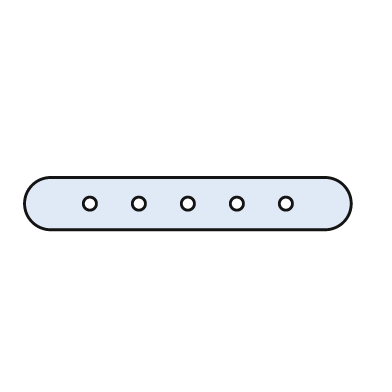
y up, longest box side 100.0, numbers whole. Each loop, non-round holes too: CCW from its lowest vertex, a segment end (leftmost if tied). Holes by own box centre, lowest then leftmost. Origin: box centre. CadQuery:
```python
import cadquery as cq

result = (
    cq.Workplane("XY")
    .moveTo(-42.0, -8.0)
    .lineTo(42.0, -8.0)
    .threePointArc((50.0, 0.0), (42.0, 8.0))
    .lineTo(-42.0, 8.0)
    .threePointArc((-50.0, 0.0), (-42.0, -8.0))
    .close()
    .moveTo(-30.0, 0.0)
    .circle(2.0)
    .moveTo(-15.0, 0.0)
    .circle(2.0)
    .moveTo(0.0, 0.0)
    .circle(2.0)
    .moveTo(15.0, 0.0)
    .circle(2.0)
    .moveTo(30.0, 0.0)
    .circle(2.0)
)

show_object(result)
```